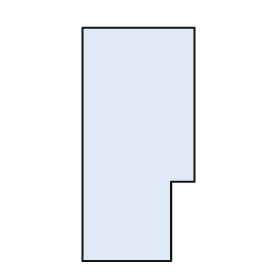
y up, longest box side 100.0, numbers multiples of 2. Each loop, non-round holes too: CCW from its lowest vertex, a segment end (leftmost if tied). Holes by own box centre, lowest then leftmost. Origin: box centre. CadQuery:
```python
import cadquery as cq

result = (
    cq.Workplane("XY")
    .moveTo(-24.0, -50.0)
    .lineTo(14.0, -50.0)
    .lineTo(14.0, -16.0)
    .lineTo(24.0, -16.0)
    .lineTo(24.0, 50.0)
    .lineTo(-24.0, 50.0)
    .close()
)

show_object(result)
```